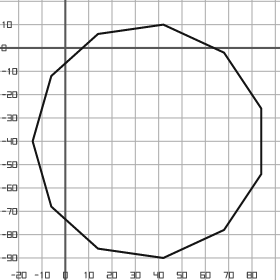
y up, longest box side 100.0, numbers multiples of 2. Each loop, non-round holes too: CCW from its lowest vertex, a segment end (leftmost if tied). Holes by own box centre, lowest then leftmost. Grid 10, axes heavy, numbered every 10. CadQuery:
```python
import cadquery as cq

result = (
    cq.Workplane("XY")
    .moveTo(42.0, -90.0)
    .lineTo(68.0, -78.0)
    .lineTo(84.0, -54.0)
    .lineTo(84.0, -26.0)
    .lineTo(68.0, -2.0)
    .lineTo(42.0, 10.0)
    .lineTo(14.0, 6.0)
    .lineTo(-6.0, -12.0)
    .lineTo(-14.0, -40.0)
    .lineTo(-6.0, -68.0)
    .lineTo(14.0, -86.0)
    .close()
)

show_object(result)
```